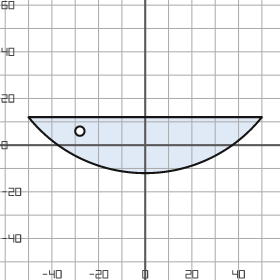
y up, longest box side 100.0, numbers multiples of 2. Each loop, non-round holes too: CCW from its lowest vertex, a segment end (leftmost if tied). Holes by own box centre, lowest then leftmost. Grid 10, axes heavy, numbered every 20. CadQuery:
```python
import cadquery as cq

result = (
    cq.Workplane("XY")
    .moveTo(-50.0, 12.0)
    .threePointArc((0.0, -12.0), (50.0, 12.0))
    .close()
    .moveTo(-28.0, 6.0)
    .circle(2.0)
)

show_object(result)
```